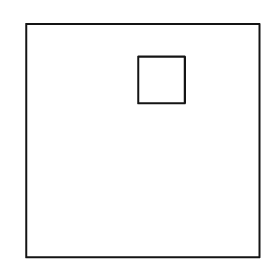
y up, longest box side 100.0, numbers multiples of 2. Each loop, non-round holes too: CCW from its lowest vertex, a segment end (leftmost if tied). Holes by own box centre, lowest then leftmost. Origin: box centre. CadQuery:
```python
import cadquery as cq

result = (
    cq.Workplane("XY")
    .moveTo(-50.0, -50.0)
    .lineTo(50.0, -50.0)
    .lineTo(50.0, 50.0)
    .lineTo(-50.0, 50.0)
    .close()
    .moveTo(-2.0, 16.0)
    .lineTo(18.0, 16.0)
    .lineTo(18.0, 36.0)
    .lineTo(-2.0, 36.0)
    .close()
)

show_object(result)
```